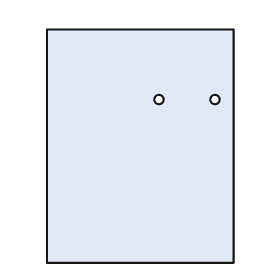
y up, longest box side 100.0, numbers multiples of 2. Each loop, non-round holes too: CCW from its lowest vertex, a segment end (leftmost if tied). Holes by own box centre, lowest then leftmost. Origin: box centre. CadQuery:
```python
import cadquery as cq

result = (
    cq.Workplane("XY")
    .moveTo(-40.0, -50.0)
    .lineTo(40.0, -50.0)
    .lineTo(40.0, 50.0)
    .lineTo(-40.0, 50.0)
    .close()
    .moveTo(8.0, 20.0)
    .circle(2.0)
    .moveTo(32.0, 20.0)
    .circle(2.0)
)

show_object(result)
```